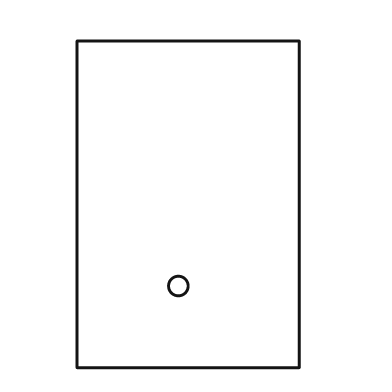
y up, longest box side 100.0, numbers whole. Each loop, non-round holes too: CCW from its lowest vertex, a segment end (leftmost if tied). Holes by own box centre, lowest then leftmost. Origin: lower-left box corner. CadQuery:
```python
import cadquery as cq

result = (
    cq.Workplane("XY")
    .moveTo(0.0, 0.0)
    .lineTo(68.0, 0.0)
    .lineTo(68.0, 100.0)
    .lineTo(0.0, 100.0)
    .close()
    .moveTo(31.0, 25.0)
    .circle(3.0)
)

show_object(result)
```